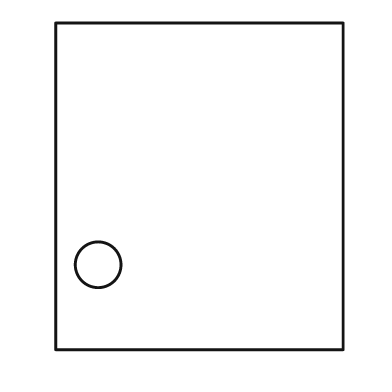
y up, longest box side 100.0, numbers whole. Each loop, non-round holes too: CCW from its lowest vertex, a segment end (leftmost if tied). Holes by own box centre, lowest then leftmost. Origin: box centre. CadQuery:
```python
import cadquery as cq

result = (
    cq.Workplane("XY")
    .moveTo(-44.0, -50.0)
    .lineTo(44.0, -50.0)
    .lineTo(44.0, 50.0)
    .lineTo(-44.0, 50.0)
    .close()
    .moveTo(-31.0, -24.0)
    .circle(7.0)
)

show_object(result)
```